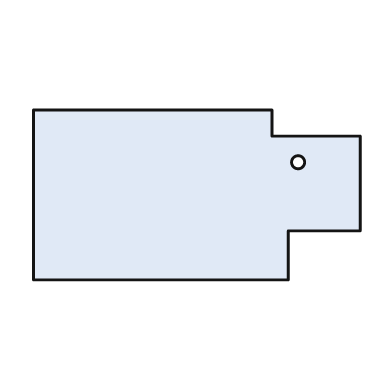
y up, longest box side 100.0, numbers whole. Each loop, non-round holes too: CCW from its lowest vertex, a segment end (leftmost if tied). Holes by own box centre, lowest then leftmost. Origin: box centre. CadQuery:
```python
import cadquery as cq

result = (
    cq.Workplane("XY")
    .moveTo(-50.0, -26.0)
    .lineTo(28.0, -26.0)
    .lineTo(28.0, -11.0)
    .lineTo(50.0, -11.0)
    .lineTo(50.0, 18.0)
    .lineTo(23.0, 18.0)
    .lineTo(23.0, 26.0)
    .lineTo(-50.0, 26.0)
    .close()
    .moveTo(31.0, 10.0)
    .circle(2.0)
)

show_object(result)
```